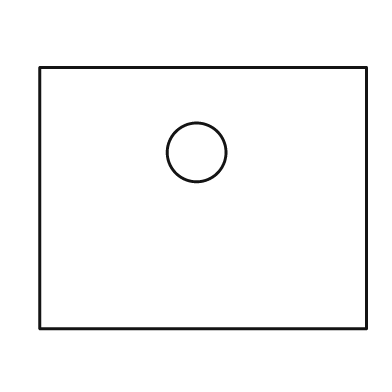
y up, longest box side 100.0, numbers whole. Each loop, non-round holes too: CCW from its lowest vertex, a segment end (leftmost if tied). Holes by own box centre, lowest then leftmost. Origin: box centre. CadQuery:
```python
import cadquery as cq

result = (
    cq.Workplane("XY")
    .moveTo(-50.0, -40.0)
    .lineTo(50.0, -40.0)
    .lineTo(50.0, 40.0)
    .lineTo(-50.0, 40.0)
    .close()
    .moveTo(-2.0, 14.0)
    .circle(9.0)
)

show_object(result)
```